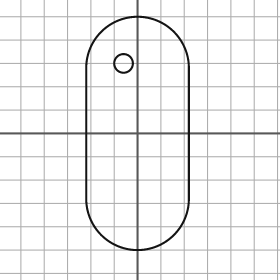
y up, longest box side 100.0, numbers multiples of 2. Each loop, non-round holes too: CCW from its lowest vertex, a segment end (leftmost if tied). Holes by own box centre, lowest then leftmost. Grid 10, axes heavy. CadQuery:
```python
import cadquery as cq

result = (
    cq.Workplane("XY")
    .moveTo(-22.0, -28.0)
    .threePointArc((0.0, -50.0), (22.0, -28.0))
    .lineTo(22.0, 28.0)
    .threePointArc((0.0, 50.0), (-22.0, 28.0))
    .close()
    .moveTo(-6.0, 30.0)
    .circle(4.0)
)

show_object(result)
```